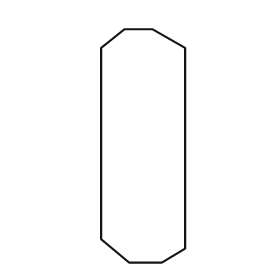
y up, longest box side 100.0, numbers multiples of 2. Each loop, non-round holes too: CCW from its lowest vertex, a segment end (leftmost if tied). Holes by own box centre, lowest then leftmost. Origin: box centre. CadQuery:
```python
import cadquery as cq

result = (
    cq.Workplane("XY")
    .moveTo(-6.0, -50.0)
    .lineTo(8.0, -50.0)
    .lineTo(18.0, -44.0)
    .lineTo(18.0, 42.0)
    .lineTo(4.0, 50.0)
    .lineTo(-8.0, 50.0)
    .lineTo(-18.0, 42.0)
    .lineTo(-18.0, -40.0)
    .close()
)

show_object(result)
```